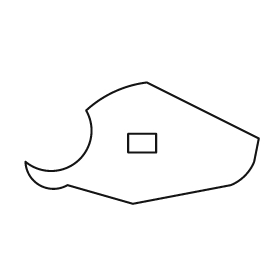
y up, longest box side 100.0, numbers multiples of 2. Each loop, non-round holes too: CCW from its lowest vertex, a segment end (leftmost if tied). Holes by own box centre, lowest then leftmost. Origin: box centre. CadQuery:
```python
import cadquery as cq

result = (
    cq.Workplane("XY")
    .moveTo(-4.0, -26.0)
    .lineTo(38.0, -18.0)
    .threePointArc((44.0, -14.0), (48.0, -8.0))
    .lineTo(50.0, 2.0)
    .lineTo(2.0, 26.0)
    .threePointArc((-12.0, 22.0), (-24.0, 14.0))
    .threePointArc((-28.0, -8.0), (-50.0, -8.0))
    .threePointArc((-44.0, -18.0), (-32.0, -18.0))
    .close()
    .moveTo(-6.0, -4.0)
    .lineTo(6.0, -4.0)
    .lineTo(6.0, 4.0)
    .lineTo(-6.0, 4.0)
    .close()
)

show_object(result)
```